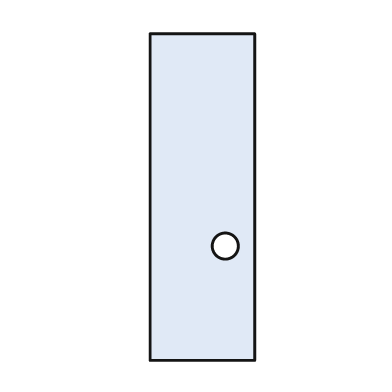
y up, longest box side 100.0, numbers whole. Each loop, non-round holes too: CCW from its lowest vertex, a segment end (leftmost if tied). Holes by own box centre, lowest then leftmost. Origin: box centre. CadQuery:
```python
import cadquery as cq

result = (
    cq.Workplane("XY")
    .moveTo(-16.0, -50.0)
    .lineTo(16.0, -50.0)
    .lineTo(16.0, 50.0)
    .lineTo(-16.0, 50.0)
    .close()
    .moveTo(7.0, -15.0)
    .circle(4.0)
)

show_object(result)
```